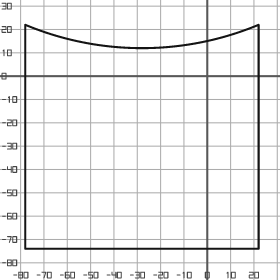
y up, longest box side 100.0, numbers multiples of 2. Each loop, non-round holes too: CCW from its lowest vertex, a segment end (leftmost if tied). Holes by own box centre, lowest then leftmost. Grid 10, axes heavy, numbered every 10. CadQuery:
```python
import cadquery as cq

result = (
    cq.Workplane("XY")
    .moveTo(-78.0, -74.0)
    .lineTo(22.0, -74.0)
    .lineTo(22.0, 22.0)
    .threePointArc((-28.0, 12.0), (-78.0, 22.0))
    .close()
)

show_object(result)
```